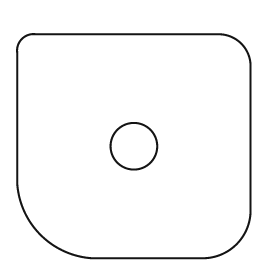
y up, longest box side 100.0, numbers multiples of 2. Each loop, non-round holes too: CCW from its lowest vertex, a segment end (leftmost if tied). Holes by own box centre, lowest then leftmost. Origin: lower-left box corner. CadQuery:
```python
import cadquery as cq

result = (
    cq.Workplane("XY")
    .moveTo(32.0, 0.0)
    .lineTo(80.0, 0.0)
    .threePointArc((94.0, 6.0), (100.0, 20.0))
    .lineTo(100.0, 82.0)
    .threePointArc((96.0, 92.0), (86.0, 96.0))
    .lineTo(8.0, 96.0)
    .threePointArc((2.0, 94.0), (0.0, 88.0))
    .lineTo(0.0, 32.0)
    .threePointArc((10.0, 10.0), (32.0, 0.0))
    .close()
    .moveTo(50.0, 48.0)
    .circle(10.0)
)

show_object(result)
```